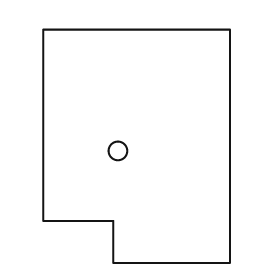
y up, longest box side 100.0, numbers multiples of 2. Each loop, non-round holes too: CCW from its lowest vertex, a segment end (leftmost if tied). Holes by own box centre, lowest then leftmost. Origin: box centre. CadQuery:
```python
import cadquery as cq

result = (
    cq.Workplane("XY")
    .moveTo(-10.0, -50.0)
    .lineTo(40.0, -50.0)
    .lineTo(40.0, 50.0)
    .lineTo(-40.0, 50.0)
    .lineTo(-40.0, -32.0)
    .lineTo(-10.0, -32.0)
    .close()
    .moveTo(-8.0, -2.0)
    .circle(4.0)
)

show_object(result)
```